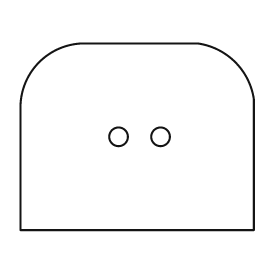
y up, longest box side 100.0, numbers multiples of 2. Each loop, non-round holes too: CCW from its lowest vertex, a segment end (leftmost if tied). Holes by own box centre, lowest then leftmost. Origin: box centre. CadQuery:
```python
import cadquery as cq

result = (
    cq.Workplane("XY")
    .moveTo(-50.0, -40.0)
    .lineTo(50.0, -40.0)
    .lineTo(50.0, 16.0)
    .threePointArc((42.0, 32.0), (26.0, 40.0))
    .lineTo(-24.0, 40.0)
    .threePointArc((-42.0, 32.0), (-50.0, 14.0))
    .close()
    .moveTo(-8.0, 0.0)
    .circle(4.0)
    .moveTo(10.0, 0.0)
    .circle(4.0)
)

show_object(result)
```